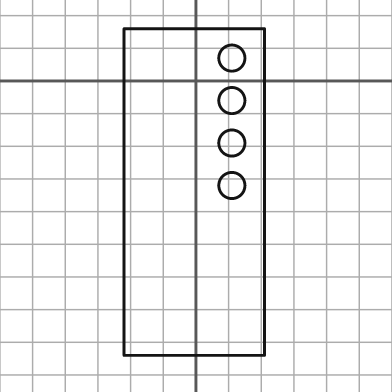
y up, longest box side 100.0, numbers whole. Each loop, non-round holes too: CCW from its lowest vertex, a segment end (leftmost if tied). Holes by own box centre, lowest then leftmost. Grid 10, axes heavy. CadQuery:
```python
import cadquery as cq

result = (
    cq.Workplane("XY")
    .moveTo(-22.0, -84.0)
    .lineTo(21.0, -84.0)
    .lineTo(21.0, 16.0)
    .lineTo(-22.0, 16.0)
    .close()
    .moveTo(11.0, -32.0)
    .circle(4.0)
    .moveTo(11.0, -19.0)
    .circle(4.0)
    .moveTo(11.0, -6.0)
    .circle(4.0)
    .moveTo(11.0, 7.0)
    .circle(4.0)
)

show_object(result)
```